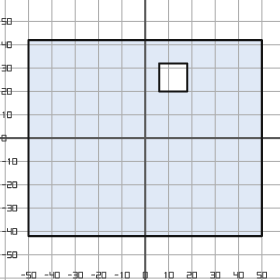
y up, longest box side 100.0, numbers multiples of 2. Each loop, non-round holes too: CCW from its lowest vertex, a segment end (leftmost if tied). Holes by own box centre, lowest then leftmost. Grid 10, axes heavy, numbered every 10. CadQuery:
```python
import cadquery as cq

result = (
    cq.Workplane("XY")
    .moveTo(-50.0, -42.0)
    .lineTo(50.0, -42.0)
    .lineTo(50.0, 42.0)
    .lineTo(-50.0, 42.0)
    .close()
    .moveTo(6.0, 20.0)
    .lineTo(18.0, 20.0)
    .lineTo(18.0, 32.0)
    .lineTo(6.0, 32.0)
    .close()
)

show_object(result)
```